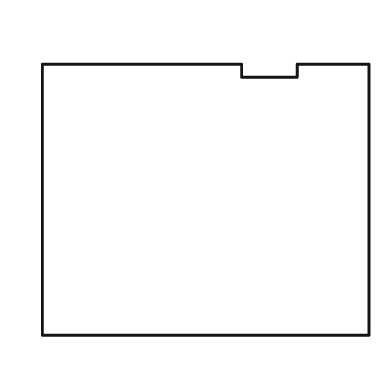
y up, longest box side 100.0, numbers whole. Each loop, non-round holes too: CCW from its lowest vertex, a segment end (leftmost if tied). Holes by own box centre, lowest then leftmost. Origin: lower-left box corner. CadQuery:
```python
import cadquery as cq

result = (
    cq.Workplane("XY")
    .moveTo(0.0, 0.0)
    .lineTo(100.0, 0.0)
    .lineTo(100.0, 83.0)
    .lineTo(78.0, 83.0)
    .lineTo(78.0, 79.0)
    .lineTo(61.0, 79.0)
    .lineTo(61.0, 83.0)
    .lineTo(0.0, 83.0)
    .close()
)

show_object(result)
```